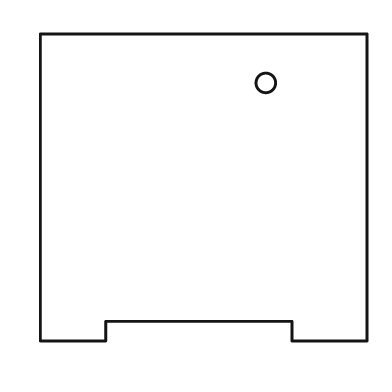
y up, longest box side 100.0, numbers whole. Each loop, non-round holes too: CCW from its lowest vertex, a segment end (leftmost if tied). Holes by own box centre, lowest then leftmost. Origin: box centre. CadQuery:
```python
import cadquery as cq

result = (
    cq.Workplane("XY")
    .moveTo(-50.0, -47.0)
    .lineTo(-30.0, -47.0)
    .lineTo(-30.0, -41.0)
    .lineTo(27.0, -41.0)
    .lineTo(27.0, -47.0)
    .lineTo(50.0, -47.0)
    .lineTo(50.0, 47.0)
    .lineTo(-50.0, 47.0)
    .close()
    .moveTo(19.0, 32.0)
    .circle(3.0)
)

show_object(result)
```